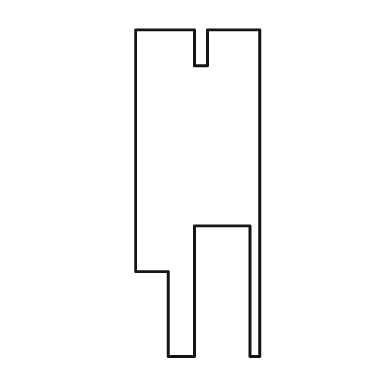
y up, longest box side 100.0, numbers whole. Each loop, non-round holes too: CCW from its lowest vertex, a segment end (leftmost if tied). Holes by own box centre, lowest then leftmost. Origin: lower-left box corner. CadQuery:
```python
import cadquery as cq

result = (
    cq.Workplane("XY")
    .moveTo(10.0, 0.0)
    .lineTo(18.0, 0.0)
    .lineTo(18.0, 40.0)
    .lineTo(35.0, 40.0)
    .lineTo(35.0, 0.0)
    .lineTo(38.0, 0.0)
    .lineTo(38.0, 100.0)
    .lineTo(22.0, 100.0)
    .lineTo(22.0, 89.0)
    .lineTo(18.0, 89.0)
    .lineTo(18.0, 100.0)
    .lineTo(0.0, 100.0)
    .lineTo(0.0, 26.0)
    .lineTo(10.0, 26.0)
    .close()
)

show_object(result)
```